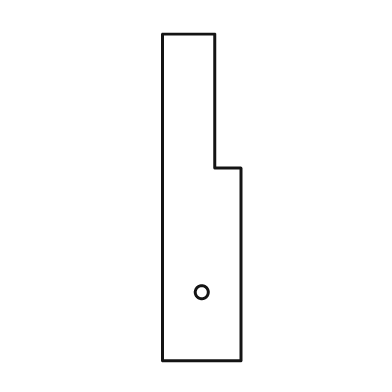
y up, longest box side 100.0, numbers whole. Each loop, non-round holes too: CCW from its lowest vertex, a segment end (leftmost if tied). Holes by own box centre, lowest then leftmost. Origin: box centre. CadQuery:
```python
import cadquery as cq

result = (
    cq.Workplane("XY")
    .moveTo(-12.0, -50.0)
    .lineTo(12.0, -50.0)
    .lineTo(12.0, 9.0)
    .lineTo(4.0, 9.0)
    .lineTo(4.0, 50.0)
    .lineTo(-12.0, 50.0)
    .close()
    .moveTo(0.0, -29.0)
    .circle(2.0)
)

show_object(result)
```